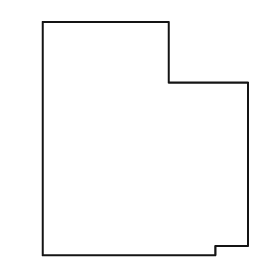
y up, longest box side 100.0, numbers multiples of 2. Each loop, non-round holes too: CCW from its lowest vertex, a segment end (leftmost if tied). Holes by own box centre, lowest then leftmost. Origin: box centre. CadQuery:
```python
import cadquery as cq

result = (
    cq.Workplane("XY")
    .moveTo(-44.0, -50.0)
    .lineTo(30.0, -50.0)
    .lineTo(30.0, -46.0)
    .lineTo(44.0, -46.0)
    .lineTo(44.0, 24.0)
    .lineTo(10.0, 24.0)
    .lineTo(10.0, 50.0)
    .lineTo(-44.0, 50.0)
    .close()
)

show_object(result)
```